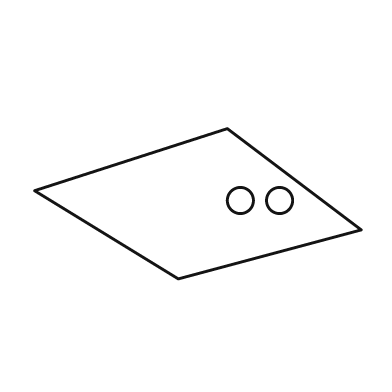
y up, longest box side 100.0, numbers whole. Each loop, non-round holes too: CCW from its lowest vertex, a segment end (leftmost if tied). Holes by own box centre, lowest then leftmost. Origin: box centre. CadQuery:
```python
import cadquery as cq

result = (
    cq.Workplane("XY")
    .moveTo(-6.0, -23.0)
    .lineTo(50.0, -8.0)
    .lineTo(9.0, 23.0)
    .lineTo(-50.0, 4.0)
    .close()
    .moveTo(13.0, 1.0)
    .circle(4.0)
    .moveTo(25.0, 1.0)
    .circle(4.0)
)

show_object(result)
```